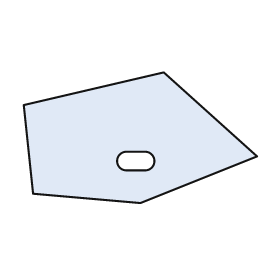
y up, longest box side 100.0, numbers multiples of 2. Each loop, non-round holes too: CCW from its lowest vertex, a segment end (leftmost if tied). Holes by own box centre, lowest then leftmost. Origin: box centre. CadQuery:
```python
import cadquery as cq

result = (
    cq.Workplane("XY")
    .moveTo(0.0, -28.0)
    .lineTo(50.0, -8.0)
    .lineTo(10.0, 28.0)
    .lineTo(-50.0, 14.0)
    .lineTo(-46.0, -24.0)
    .close()
    .moveTo(-6.0, -14.0)
    .lineTo(2.0, -14.0)
    .threePointArc((6.0, -10.0), (2.0, -6.0))
    .lineTo(-6.0, -6.0)
    .threePointArc((-10.0, -10.0), (-6.0, -14.0))
    .close()
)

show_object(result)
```